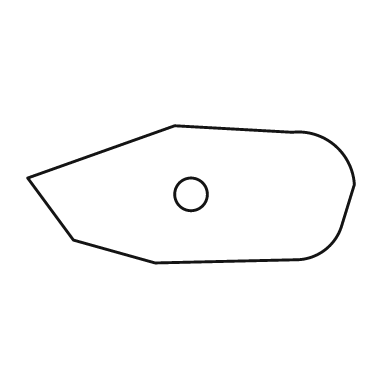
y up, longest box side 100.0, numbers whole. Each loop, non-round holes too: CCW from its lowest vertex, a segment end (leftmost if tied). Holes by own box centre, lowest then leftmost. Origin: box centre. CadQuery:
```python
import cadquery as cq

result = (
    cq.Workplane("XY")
    .moveTo(-11.0, -21.0)
    .lineTo(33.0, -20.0)
    .threePointArc((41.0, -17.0), (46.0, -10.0))
    .lineTo(50.0, 3.0)
    .threePointArc((44.0, 15.0), (31.0, 19.0))
    .lineTo(-5.0, 21.0)
    .lineTo(-50.0, 5.0)
    .lineTo(-36.0, -14.0)
    .close()
    .moveTo(0.0, 0.0)
    .circle(5.0)
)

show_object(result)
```